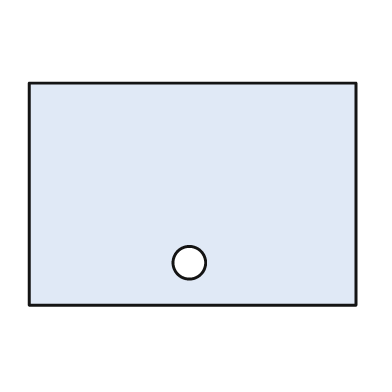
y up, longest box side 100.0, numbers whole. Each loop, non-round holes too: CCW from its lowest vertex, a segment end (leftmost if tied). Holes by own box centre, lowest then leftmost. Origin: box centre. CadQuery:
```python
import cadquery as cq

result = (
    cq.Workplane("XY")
    .moveTo(-50.0, -34.0)
    .lineTo(50.0, -34.0)
    .lineTo(50.0, 34.0)
    .lineTo(-50.0, 34.0)
    .close()
    .moveTo(-1.0, -21.0)
    .circle(5.0)
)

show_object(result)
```